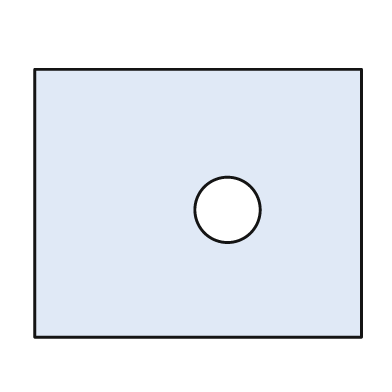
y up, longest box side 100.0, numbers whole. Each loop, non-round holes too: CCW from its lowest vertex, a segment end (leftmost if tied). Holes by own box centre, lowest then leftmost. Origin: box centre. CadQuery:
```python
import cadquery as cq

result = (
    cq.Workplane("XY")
    .moveTo(-50.0, -41.0)
    .lineTo(50.0, -41.0)
    .lineTo(50.0, 41.0)
    .lineTo(-50.0, 41.0)
    .close()
    .moveTo(9.0, -2.0)
    .circle(10.0)
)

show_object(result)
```